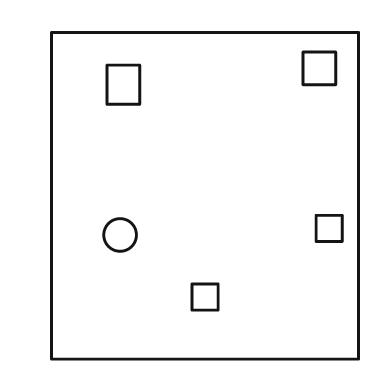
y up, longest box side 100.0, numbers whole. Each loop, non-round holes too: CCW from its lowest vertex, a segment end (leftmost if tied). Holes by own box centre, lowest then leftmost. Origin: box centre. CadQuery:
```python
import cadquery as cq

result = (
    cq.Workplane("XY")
    .moveTo(-47.0, -50.0)
    .lineTo(47.0, -50.0)
    .lineTo(47.0, 50.0)
    .lineTo(-47.0, 50.0)
    .close()
    .moveTo(-4.0, -35.0)
    .lineTo(4.0, -35.0)
    .lineTo(4.0, -27.0)
    .lineTo(-4.0, -27.0)
    .close()
    .moveTo(-26.0, -12.0)
    .circle(5.0)
    .moveTo(34.0, -14.0)
    .lineTo(42.0, -14.0)
    .lineTo(42.0, -6.0)
    .lineTo(34.0, -6.0)
    .close()
    .moveTo(-30.0, 28.0)
    .lineTo(-20.0, 28.0)
    .lineTo(-20.0, 40.0)
    .lineTo(-30.0, 40.0)
    .close()
    .moveTo(30.0, 34.0)
    .lineTo(40.0, 34.0)
    .lineTo(40.0, 44.0)
    .lineTo(30.0, 44.0)
    .close()
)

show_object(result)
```